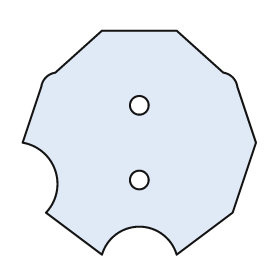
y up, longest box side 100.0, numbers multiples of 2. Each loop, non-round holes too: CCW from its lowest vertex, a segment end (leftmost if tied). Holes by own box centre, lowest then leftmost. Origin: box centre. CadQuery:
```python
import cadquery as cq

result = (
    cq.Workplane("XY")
    .moveTo(-16.0, -48.0)
    .threePointArc((0.0, -36.0), (16.0, -48.0))
    .lineTo(40.0, -30.0)
    .lineTo(50.0, 0.0)
    .lineTo(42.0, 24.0)
    .threePointArc((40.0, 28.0), (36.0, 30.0))
    .lineTo(16.0, 48.0)
    .lineTo(-16.0, 48.0)
    .lineTo(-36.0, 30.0)
    .threePointArc((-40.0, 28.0), (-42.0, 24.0))
    .lineTo(-50.0, 0.0)
    .threePointArc((-36.0, -12.0), (-40.0, -30.0))
    .close()
    .moveTo(0.0, -16.0)
    .circle(4.0)
    .moveTo(0.0, 16.0)
    .circle(4.0)
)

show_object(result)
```